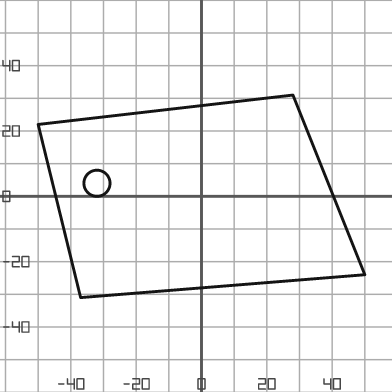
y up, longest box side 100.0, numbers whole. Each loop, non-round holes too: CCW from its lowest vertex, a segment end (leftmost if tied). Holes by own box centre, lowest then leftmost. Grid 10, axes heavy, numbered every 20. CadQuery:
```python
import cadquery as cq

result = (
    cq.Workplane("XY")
    .moveTo(-37.0, -31.0)
    .lineTo(50.0, -24.0)
    .lineTo(28.0, 31.0)
    .lineTo(-50.0, 22.0)
    .close()
    .moveTo(-32.0, 4.0)
    .circle(4.0)
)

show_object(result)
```